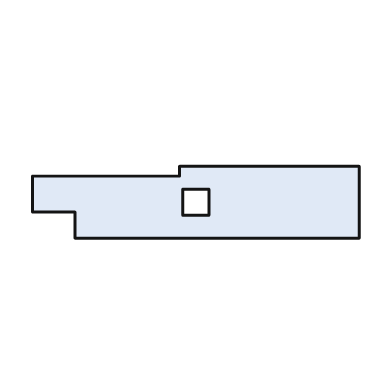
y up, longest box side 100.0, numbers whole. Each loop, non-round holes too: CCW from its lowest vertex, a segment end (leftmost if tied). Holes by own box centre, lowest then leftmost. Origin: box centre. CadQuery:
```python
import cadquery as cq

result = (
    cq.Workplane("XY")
    .moveTo(-37.0, -11.0)
    .lineTo(50.0, -11.0)
    .lineTo(50.0, 11.0)
    .lineTo(-5.0, 11.0)
    .lineTo(-5.0, 8.0)
    .lineTo(-50.0, 8.0)
    .lineTo(-50.0, -3.0)
    .lineTo(-37.0, -3.0)
    .close()
    .moveTo(-4.0, -4.0)
    .lineTo(4.0, -4.0)
    .lineTo(4.0, 4.0)
    .lineTo(-4.0, 4.0)
    .close()
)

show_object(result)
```